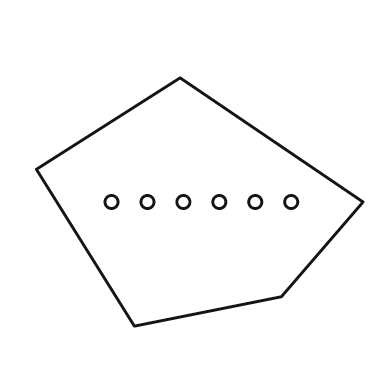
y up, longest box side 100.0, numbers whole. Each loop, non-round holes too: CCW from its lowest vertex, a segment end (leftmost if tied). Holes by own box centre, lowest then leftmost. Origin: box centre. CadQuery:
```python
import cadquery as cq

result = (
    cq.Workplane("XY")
    .moveTo(-20.0, -38.0)
    .lineTo(25.0, -29.0)
    .lineTo(50.0, 0.0)
    .lineTo(-6.0, 38.0)
    .lineTo(-50.0, 10.0)
    .close()
    .moveTo(-27.0, 0.0)
    .circle(2.0)
    .moveTo(-16.0, 0.0)
    .circle(2.0)
    .moveTo(-5.0, 0.0)
    .circle(2.0)
    .moveTo(6.0, 0.0)
    .circle(2.0)
    .moveTo(17.0, 0.0)
    .circle(2.0)
    .moveTo(28.0, 0.0)
    .circle(2.0)
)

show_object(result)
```